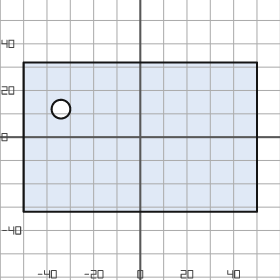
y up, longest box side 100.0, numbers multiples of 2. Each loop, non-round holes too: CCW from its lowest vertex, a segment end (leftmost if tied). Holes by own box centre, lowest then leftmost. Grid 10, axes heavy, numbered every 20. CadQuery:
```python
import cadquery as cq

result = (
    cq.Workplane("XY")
    .moveTo(-50.0, -32.0)
    .lineTo(50.0, -32.0)
    .lineTo(50.0, 32.0)
    .lineTo(-50.0, 32.0)
    .close()
    .moveTo(-34.0, 12.0)
    .circle(4.0)
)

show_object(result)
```